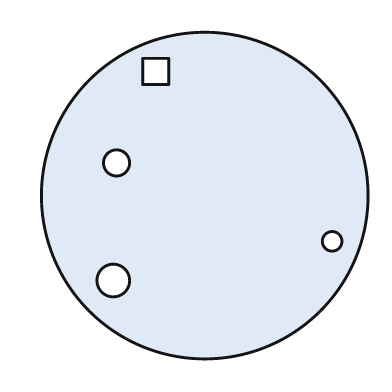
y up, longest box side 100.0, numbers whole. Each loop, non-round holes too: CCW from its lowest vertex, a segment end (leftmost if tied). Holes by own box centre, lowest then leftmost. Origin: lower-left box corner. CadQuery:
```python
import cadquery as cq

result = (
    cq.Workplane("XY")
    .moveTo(50.0, 50.0)
    .circle(50.0)
    .moveTo(22.0, 24.0)
    .circle(5.0)
    .moveTo(89.0, 36.0)
    .circle(3.0)
    .moveTo(23.0, 60.0)
    .circle(4.0)
    .moveTo(31.0, 84.0)
    .lineTo(39.0, 84.0)
    .lineTo(39.0, 92.0)
    .lineTo(31.0, 92.0)
    .close()
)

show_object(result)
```